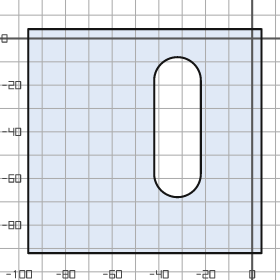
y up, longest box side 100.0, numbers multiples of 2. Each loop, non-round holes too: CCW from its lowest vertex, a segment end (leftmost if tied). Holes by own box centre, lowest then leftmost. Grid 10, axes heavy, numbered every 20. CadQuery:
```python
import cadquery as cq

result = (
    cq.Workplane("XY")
    .moveTo(-96.0, -92.0)
    .lineTo(4.0, -92.0)
    .lineTo(4.0, 4.0)
    .lineTo(-96.0, 4.0)
    .close()
    .moveTo(-42.0, -58.0)
    .threePointArc((-32.0, -68.0), (-22.0, -58.0))
    .lineTo(-22.0, -18.0)
    .threePointArc((-32.0, -8.0), (-42.0, -18.0))
    .close()
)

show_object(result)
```